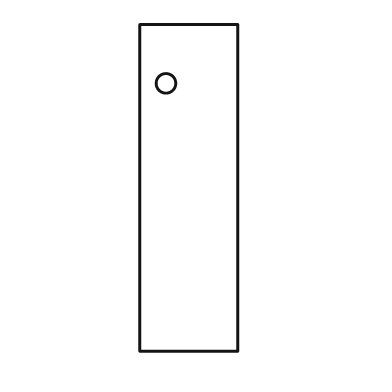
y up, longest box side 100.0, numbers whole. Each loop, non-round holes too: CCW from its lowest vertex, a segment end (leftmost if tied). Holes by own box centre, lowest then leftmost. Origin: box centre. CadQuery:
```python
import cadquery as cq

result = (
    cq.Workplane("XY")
    .moveTo(-15.0, -50.0)
    .lineTo(15.0, -50.0)
    .lineTo(15.0, 50.0)
    .lineTo(-15.0, 50.0)
    .close()
    .moveTo(-7.0, 32.0)
    .circle(3.0)
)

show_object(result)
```